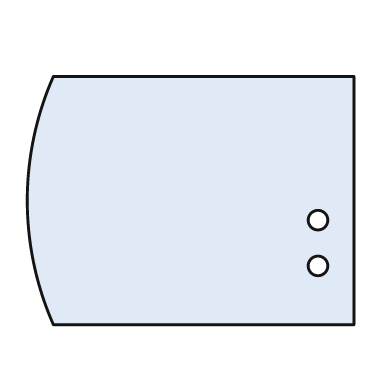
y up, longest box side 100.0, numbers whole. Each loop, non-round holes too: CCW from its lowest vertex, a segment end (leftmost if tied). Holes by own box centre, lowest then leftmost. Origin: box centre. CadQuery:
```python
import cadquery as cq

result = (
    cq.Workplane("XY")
    .moveTo(-42.0, -38.0)
    .lineTo(50.0, -38.0)
    .lineTo(50.0, 38.0)
    .lineTo(-42.0, 38.0)
    .threePointArc((-50.0, 0.0), (-42.0, -38.0))
    .close()
    .moveTo(39.0, -20.0)
    .circle(3.0)
    .moveTo(39.0, -6.0)
    .circle(3.0)
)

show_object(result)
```